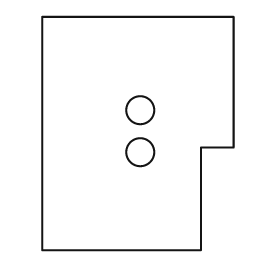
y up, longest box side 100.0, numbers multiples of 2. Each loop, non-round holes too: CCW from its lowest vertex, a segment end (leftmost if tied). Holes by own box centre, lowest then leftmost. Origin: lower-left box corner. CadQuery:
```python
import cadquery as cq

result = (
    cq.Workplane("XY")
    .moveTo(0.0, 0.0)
    .lineTo(68.0, 0.0)
    .lineTo(68.0, 44.0)
    .lineTo(82.0, 44.0)
    .lineTo(82.0, 100.0)
    .lineTo(0.0, 100.0)
    .close()
    .moveTo(42.0, 42.0)
    .circle(6.0)
    .moveTo(42.0, 60.0)
    .circle(6.0)
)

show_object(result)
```